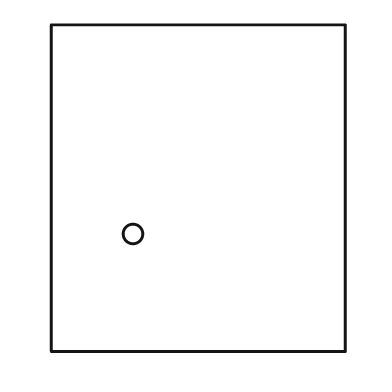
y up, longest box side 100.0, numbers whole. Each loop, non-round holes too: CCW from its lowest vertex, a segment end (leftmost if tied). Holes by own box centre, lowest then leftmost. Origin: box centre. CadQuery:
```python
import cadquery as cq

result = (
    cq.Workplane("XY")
    .moveTo(-45.0, -50.0)
    .lineTo(45.0, -50.0)
    .lineTo(45.0, 50.0)
    .lineTo(-45.0, 50.0)
    .close()
    .moveTo(-20.0, -14.0)
    .circle(3.0)
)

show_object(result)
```